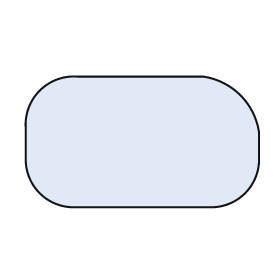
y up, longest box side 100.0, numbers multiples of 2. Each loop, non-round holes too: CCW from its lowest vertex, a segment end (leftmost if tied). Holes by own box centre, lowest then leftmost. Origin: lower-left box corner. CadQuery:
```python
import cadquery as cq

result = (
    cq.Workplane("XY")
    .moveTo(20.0, 0.0)
    .lineTo(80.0, 0.0)
    .threePointArc((94.0, 6.0), (100.0, 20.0))
    .lineTo(100.0, 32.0)
    .threePointArc((92.0, 48.0), (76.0, 56.0))
    .lineTo(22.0, 56.0)
    .threePointArc((6.0, 50.0), (0.0, 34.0))
    .lineTo(0.0, 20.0)
    .threePointArc((6.0, 6.0), (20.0, 0.0))
    .close()
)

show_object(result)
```